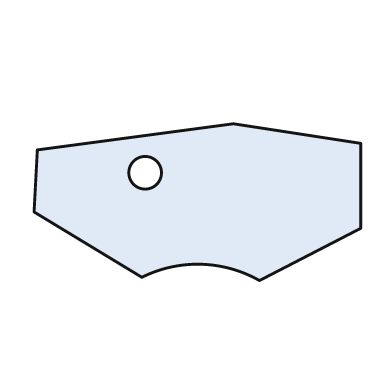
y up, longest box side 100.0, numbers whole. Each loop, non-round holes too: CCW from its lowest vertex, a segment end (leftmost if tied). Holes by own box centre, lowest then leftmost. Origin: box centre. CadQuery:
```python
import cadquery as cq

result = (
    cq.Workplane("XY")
    .moveTo(19.0, -24.0)
    .lineTo(50.0, -8.0)
    .lineTo(50.0, 18.0)
    .lineTo(11.0, 24.0)
    .lineTo(-49.0, 16.0)
    .lineTo(-50.0, -3.0)
    .lineTo(-17.0, -23.0)
    .threePointArc((1.0, -19.0), (19.0, -24.0))
    .close()
    .moveTo(-16.0, 9.0)
    .circle(5.0)
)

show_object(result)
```